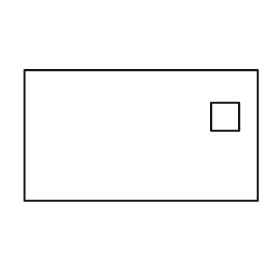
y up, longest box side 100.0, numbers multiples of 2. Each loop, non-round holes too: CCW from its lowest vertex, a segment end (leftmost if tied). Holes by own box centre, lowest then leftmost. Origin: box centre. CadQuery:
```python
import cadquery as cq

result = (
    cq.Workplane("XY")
    .moveTo(-50.0, -28.0)
    .lineTo(50.0, -28.0)
    .lineTo(50.0, 28.0)
    .lineTo(-50.0, 28.0)
    .close()
    .moveTo(30.0, 2.0)
    .lineTo(42.0, 2.0)
    .lineTo(42.0, 14.0)
    .lineTo(30.0, 14.0)
    .close()
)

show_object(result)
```